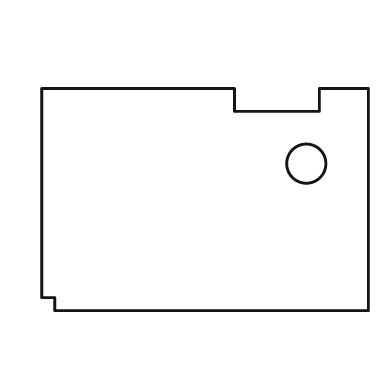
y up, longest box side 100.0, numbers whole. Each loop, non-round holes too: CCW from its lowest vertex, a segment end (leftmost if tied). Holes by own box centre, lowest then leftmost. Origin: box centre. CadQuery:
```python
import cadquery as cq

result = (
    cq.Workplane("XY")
    .moveTo(-46.0, -34.0)
    .lineTo(50.0, -34.0)
    .lineTo(50.0, 34.0)
    .lineTo(35.0, 34.0)
    .lineTo(35.0, 27.0)
    .lineTo(9.0, 27.0)
    .lineTo(9.0, 34.0)
    .lineTo(-50.0, 34.0)
    .lineTo(-50.0, -30.0)
    .lineTo(-46.0, -30.0)
    .close()
    .moveTo(31.0, 11.0)
    .circle(6.0)
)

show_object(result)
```